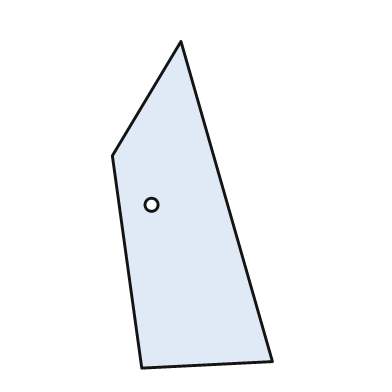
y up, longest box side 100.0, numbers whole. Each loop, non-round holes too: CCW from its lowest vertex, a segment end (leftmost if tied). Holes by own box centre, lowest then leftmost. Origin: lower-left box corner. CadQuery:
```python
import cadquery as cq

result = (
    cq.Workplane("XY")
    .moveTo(9.0, 0.0)
    .lineTo(49.0, 2.0)
    .lineTo(21.0, 100.0)
    .lineTo(0.0, 65.0)
    .close()
    .moveTo(12.0, 50.0)
    .circle(2.0)
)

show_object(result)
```